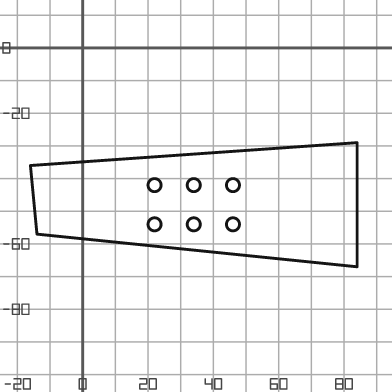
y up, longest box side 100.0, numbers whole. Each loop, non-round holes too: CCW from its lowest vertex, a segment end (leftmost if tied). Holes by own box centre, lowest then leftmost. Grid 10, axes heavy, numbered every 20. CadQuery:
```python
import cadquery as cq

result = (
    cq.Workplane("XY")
    .moveTo(84.0, -67.0)
    .lineTo(84.0, -29.0)
    .lineTo(-16.0, -36.0)
    .lineTo(-14.0, -57.0)
    .close()
    .moveTo(22.0, -54.0)
    .circle(2.0)
    .moveTo(34.0, -54.0)
    .circle(2.0)
    .moveTo(46.0, -54.0)
    .circle(2.0)
    .moveTo(22.0, -42.0)
    .circle(2.0)
    .moveTo(34.0, -42.0)
    .circle(2.0)
    .moveTo(46.0, -42.0)
    .circle(2.0)
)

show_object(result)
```